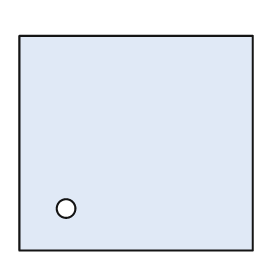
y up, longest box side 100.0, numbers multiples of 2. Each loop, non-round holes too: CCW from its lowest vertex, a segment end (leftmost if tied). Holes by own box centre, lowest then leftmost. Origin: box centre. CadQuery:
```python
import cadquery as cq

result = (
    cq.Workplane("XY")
    .moveTo(-50.0, -46.0)
    .lineTo(50.0, -46.0)
    .lineTo(50.0, 46.0)
    .lineTo(-50.0, 46.0)
    .close()
    .moveTo(-30.0, -28.0)
    .circle(4.0)
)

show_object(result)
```